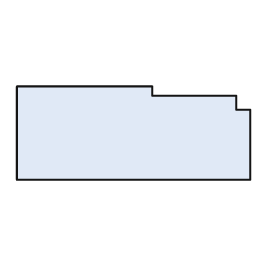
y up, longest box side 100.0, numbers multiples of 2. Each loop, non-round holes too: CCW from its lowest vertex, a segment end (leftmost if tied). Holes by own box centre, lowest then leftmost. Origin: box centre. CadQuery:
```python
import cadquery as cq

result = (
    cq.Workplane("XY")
    .moveTo(-50.0, -20.0)
    .lineTo(50.0, -20.0)
    .lineTo(50.0, 10.0)
    .lineTo(44.0, 10.0)
    .lineTo(44.0, 16.0)
    .lineTo(8.0, 16.0)
    .lineTo(8.0, 20.0)
    .lineTo(-50.0, 20.0)
    .close()
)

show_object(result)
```